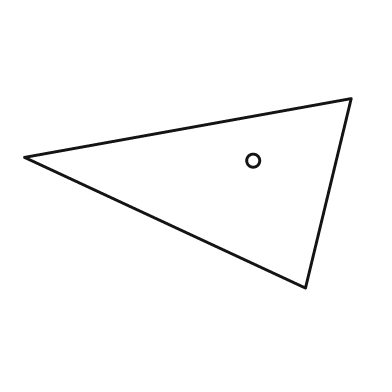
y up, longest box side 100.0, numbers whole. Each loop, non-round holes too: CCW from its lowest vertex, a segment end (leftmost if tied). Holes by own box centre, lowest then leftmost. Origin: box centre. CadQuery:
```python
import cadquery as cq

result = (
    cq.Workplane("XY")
    .moveTo(36.0, -29.0)
    .lineTo(50.0, 29.0)
    .lineTo(-50.0, 11.0)
    .close()
    .moveTo(20.0, 10.0)
    .circle(2.0)
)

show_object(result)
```